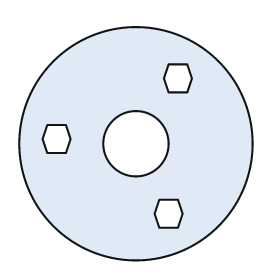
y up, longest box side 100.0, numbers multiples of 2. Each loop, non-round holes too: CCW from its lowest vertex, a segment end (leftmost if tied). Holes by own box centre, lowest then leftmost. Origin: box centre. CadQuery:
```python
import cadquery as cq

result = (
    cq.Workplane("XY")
    .moveTo(0.0, 0.0)
    .circle(50.0)
    .moveTo(10.0, -36.0)
    .lineTo(18.0, -36.0)
    .lineTo(20.0, -30.0)
    .lineTo(18.0, -24.0)
    .lineTo(10.0, -24.0)
    .lineTo(8.0, -30.0)
    .close()
    .moveTo(0.0, 0.0)
    .circle(14.0)
    .moveTo(-38.0, -4.0)
    .lineTo(-30.0, -4.0)
    .lineTo(-28.0, 2.0)
    .lineTo(-30.0, 8.0)
    .lineTo(-38.0, 8.0)
    .lineTo(-40.0, 2.0)
    .close()
    .moveTo(14.0, 22.0)
    .lineTo(22.0, 22.0)
    .lineTo(24.0, 28.0)
    .lineTo(22.0, 34.0)
    .lineTo(14.0, 34.0)
    .lineTo(12.0, 28.0)
    .close()
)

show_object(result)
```